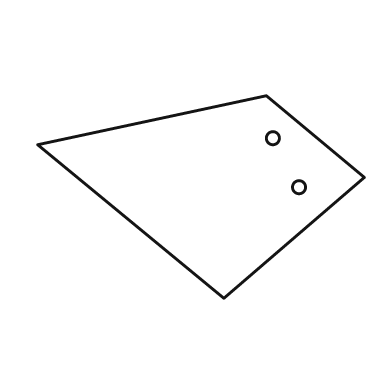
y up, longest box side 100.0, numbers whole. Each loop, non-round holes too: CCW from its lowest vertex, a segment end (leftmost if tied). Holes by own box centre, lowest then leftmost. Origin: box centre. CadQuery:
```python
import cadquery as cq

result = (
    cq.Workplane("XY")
    .moveTo(7.0, -31.0)
    .lineTo(50.0, 6.0)
    .lineTo(20.0, 31.0)
    .lineTo(-50.0, 16.0)
    .close()
    .moveTo(30.0, 3.0)
    .circle(2.0)
    .moveTo(22.0, 18.0)
    .circle(2.0)
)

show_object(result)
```